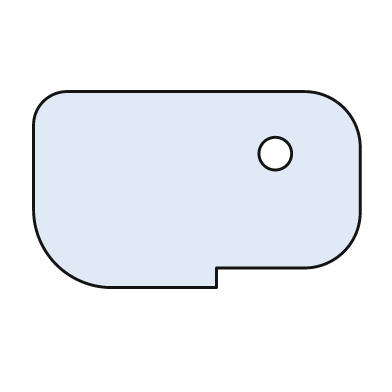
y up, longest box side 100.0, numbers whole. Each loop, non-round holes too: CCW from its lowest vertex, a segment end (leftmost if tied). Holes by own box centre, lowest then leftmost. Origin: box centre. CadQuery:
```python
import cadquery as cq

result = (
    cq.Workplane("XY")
    .moveTo(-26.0, -30.0)
    .lineTo(6.0, -30.0)
    .lineTo(6.0, -24.0)
    .lineTo(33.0, -24.0)
    .threePointArc((45.0, -19.0), (50.0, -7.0))
    .lineTo(50.0, 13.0)
    .threePointArc((45.0, 25.0), (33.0, 30.0))
    .lineTo(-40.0, 30.0)
    .threePointArc((-47.0, 27.0), (-50.0, 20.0))
    .lineTo(-50.0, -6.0)
    .threePointArc((-43.0, -23.0), (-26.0, -30.0))
    .close()
    .moveTo(24.0, 11.0)
    .circle(5.0)
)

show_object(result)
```